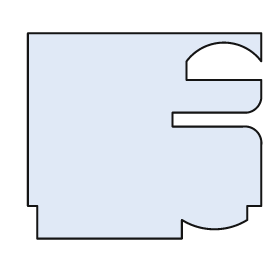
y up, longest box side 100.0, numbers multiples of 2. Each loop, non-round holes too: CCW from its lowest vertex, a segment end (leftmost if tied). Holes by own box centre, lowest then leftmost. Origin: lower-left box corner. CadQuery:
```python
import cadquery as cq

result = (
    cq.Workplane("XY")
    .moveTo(4.0, 0.0)
    .lineTo(66.0, 0.0)
    .lineTo(66.0, 8.0)
    .threePointArc((80.0, 4.0), (94.0, 8.0))
    .lineTo(94.0, 14.0)
    .lineTo(100.0, 14.0)
    .lineTo(100.0, 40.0)
    .threePointArc((98.0, 46.0), (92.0, 48.0))
    .lineTo(62.0, 48.0)
    .lineTo(62.0, 54.0)
    .lineTo(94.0, 54.0)
    .threePointArc((98.0, 56.0), (100.0, 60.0))
    .lineTo(100.0, 68.0)
    .lineTo(68.0, 68.0)
    .lineTo(68.0, 76.0)
    .threePointArc((84.0, 84.0), (100.0, 76.0))
    .lineTo(100.0, 88.0)
    .lineTo(0.0, 88.0)
    .lineTo(0.0, 14.0)
    .lineTo(4.0, 14.0)
    .close()
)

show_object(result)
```